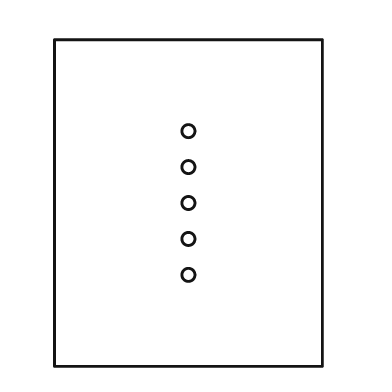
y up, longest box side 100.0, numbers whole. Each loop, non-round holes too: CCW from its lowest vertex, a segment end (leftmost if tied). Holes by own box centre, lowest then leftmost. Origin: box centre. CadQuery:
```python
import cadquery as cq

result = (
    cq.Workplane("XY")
    .moveTo(-41.0, -50.0)
    .lineTo(41.0, -50.0)
    .lineTo(41.0, 50.0)
    .lineTo(-41.0, 50.0)
    .close()
    .moveTo(0.0, -22.0)
    .circle(2.0)
    .moveTo(0.0, -11.0)
    .circle(2.0)
    .moveTo(0.0, 0.0)
    .circle(2.0)
    .moveTo(0.0, 11.0)
    .circle(2.0)
    .moveTo(0.0, 22.0)
    .circle(2.0)
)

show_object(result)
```